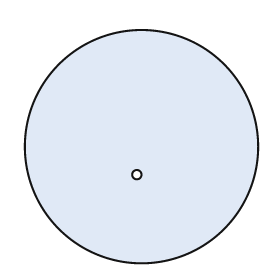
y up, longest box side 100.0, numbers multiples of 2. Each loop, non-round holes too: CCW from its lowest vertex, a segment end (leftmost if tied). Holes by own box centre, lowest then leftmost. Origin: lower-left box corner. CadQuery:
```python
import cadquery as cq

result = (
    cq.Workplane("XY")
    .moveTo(50.0, 50.0)
    .circle(50.0)
    .moveTo(48.0, 38.0)
    .circle(2.0)
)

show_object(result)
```